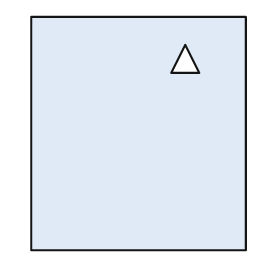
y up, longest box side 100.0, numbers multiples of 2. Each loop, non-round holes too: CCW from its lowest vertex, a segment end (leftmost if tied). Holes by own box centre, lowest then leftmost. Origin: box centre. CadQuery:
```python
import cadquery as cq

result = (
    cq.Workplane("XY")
    .moveTo(-46.0, -50.0)
    .lineTo(46.0, -50.0)
    .lineTo(46.0, 50.0)
    .lineTo(-46.0, 50.0)
    .close()
    .moveTo(14.0, 26.0)
    .lineTo(26.0, 26.0)
    .lineTo(20.0, 38.0)
    .close()
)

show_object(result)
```